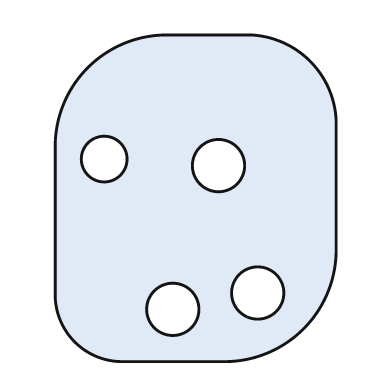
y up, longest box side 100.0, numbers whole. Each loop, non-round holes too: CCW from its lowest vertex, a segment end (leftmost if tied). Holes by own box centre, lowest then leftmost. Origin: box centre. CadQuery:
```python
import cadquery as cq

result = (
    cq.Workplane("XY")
    .moveTo(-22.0, -50.0)
    .lineTo(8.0, -50.0)
    .threePointArc((33.0, -40.0), (43.0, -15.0))
    .lineTo(43.0, 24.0)
    .threePointArc((35.0, 42.0), (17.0, 50.0))
    .lineTo(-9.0, 50.0)
    .threePointArc((-33.0, 40.0), (-43.0, 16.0))
    .lineTo(-43.0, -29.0)
    .threePointArc((-37.0, -44.0), (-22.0, -50.0))
    .close()
    .moveTo(-7.0, -34.0)
    .circle(8.0)
    .moveTo(19.0, -29.0)
    .circle(8.0)
    .moveTo(7.0, 10.0)
    .circle(8.0)
    .moveTo(-28.0, 12.0)
    .circle(7.0)
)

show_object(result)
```